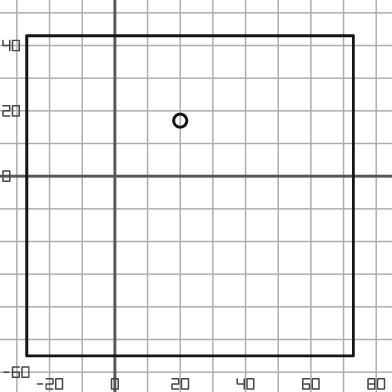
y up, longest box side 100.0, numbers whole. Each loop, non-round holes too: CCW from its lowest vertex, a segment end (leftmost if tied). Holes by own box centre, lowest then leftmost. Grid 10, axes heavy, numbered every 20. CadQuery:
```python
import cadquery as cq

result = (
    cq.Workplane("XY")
    .moveTo(-27.0, -55.0)
    .lineTo(73.0, -55.0)
    .lineTo(73.0, 43.0)
    .lineTo(-27.0, 43.0)
    .close()
    .moveTo(20.0, 17.0)
    .circle(2.0)
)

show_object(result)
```